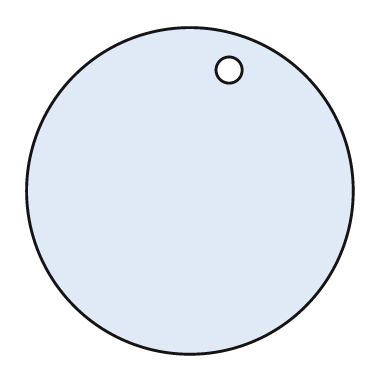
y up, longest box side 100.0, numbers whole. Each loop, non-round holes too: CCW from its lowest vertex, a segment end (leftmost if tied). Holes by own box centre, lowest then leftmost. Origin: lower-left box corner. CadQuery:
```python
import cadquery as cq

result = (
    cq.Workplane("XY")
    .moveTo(50.0, 50.0)
    .circle(50.0)
    .moveTo(62.0, 87.0)
    .circle(4.0)
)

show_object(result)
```